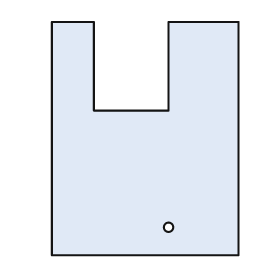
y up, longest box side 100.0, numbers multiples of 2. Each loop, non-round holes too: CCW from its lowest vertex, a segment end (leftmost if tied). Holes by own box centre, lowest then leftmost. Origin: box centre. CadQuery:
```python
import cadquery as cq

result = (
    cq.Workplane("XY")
    .moveTo(-40.0, -50.0)
    .lineTo(40.0, -50.0)
    .lineTo(40.0, 50.0)
    .lineTo(10.0, 50.0)
    .lineTo(10.0, 12.0)
    .lineTo(-22.0, 12.0)
    .lineTo(-22.0, 50.0)
    .lineTo(-40.0, 50.0)
    .close()
    .moveTo(10.0, -38.0)
    .circle(2.0)
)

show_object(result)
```